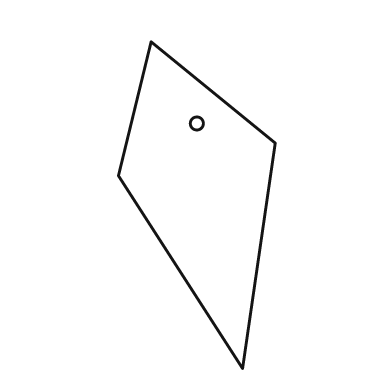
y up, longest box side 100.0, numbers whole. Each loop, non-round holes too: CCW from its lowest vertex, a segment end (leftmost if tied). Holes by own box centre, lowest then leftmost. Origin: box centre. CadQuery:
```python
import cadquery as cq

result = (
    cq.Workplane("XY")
    .moveTo(14.0, -50.0)
    .lineTo(24.0, 19.0)
    .lineTo(-14.0, 50.0)
    .lineTo(-24.0, 9.0)
    .close()
    .moveTo(0.0, 25.0)
    .circle(2.0)
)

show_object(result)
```